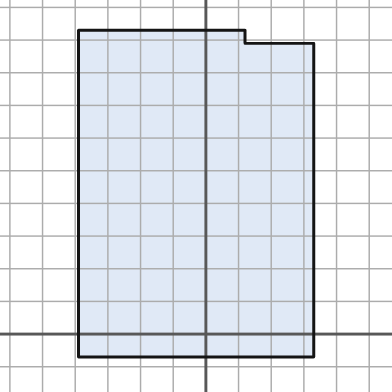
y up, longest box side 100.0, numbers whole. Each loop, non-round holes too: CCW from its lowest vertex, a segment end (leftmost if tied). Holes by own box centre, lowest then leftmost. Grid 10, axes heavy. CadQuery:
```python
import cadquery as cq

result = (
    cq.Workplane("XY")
    .moveTo(-39.0, -7.0)
    .lineTo(33.0, -7.0)
    .lineTo(33.0, 89.0)
    .lineTo(12.0, 89.0)
    .lineTo(12.0, 93.0)
    .lineTo(-39.0, 93.0)
    .close()
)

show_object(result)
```